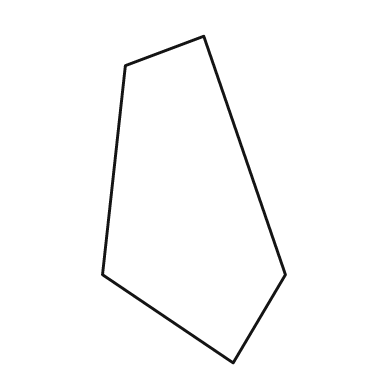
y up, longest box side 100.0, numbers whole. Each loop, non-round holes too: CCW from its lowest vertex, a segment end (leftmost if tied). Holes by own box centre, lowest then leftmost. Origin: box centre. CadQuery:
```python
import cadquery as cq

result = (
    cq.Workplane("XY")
    .moveTo(12.0, -50.0)
    .lineTo(28.0, -23.0)
    .lineTo(3.0, 50.0)
    .lineTo(-21.0, 41.0)
    .lineTo(-28.0, -23.0)
    .close()
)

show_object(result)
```